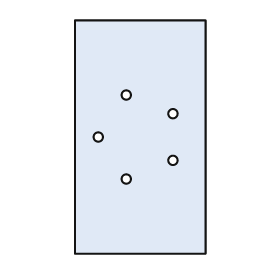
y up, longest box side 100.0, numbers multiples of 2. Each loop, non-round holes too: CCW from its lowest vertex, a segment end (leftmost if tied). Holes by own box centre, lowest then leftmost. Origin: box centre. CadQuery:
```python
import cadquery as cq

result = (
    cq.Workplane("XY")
    .moveTo(-28.0, -50.0)
    .lineTo(28.0, -50.0)
    .lineTo(28.0, 50.0)
    .lineTo(-28.0, 50.0)
    .close()
    .moveTo(-6.0, -18.0)
    .circle(2.0)
    .moveTo(14.0, -10.0)
    .circle(2.0)
    .moveTo(-18.0, 0.0)
    .circle(2.0)
    .moveTo(14.0, 10.0)
    .circle(2.0)
    .moveTo(-6.0, 18.0)
    .circle(2.0)
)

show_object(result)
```